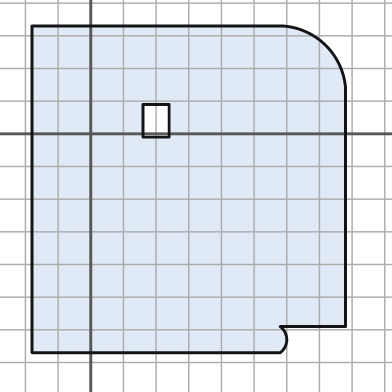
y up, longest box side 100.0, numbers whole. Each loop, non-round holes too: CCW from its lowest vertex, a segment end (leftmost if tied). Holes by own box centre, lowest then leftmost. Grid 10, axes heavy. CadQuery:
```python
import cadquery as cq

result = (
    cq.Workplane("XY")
    .moveTo(-18.0, -67.0)
    .lineTo(58.0, -67.0)
    .threePointArc((60.0, -63.0), (58.0, -59.0))
    .lineTo(78.0, -59.0)
    .lineTo(78.0, 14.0)
    .threePointArc((72.0, 27.0), (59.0, 33.0))
    .lineTo(-18.0, 33.0)
    .close()
    .moveTo(16.0, -1.0)
    .lineTo(24.0, -1.0)
    .lineTo(24.0, 9.0)
    .lineTo(16.0, 9.0)
    .close()
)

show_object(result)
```